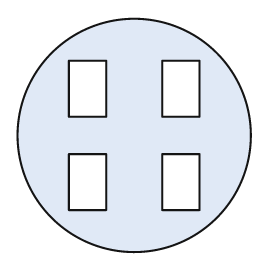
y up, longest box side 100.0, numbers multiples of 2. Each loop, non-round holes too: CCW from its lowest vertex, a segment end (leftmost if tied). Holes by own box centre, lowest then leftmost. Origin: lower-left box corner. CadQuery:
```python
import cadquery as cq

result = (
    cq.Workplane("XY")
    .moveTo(50.0, 50.0)
    .circle(50.0)
    .moveTo(22.0, 18.0)
    .lineTo(38.0, 18.0)
    .lineTo(38.0, 42.0)
    .lineTo(22.0, 42.0)
    .close()
    .moveTo(62.0, 18.0)
    .lineTo(78.0, 18.0)
    .lineTo(78.0, 42.0)
    .lineTo(62.0, 42.0)
    .close()
    .moveTo(22.0, 58.0)
    .lineTo(38.0, 58.0)
    .lineTo(38.0, 82.0)
    .lineTo(22.0, 82.0)
    .close()
    .moveTo(62.0, 58.0)
    .lineTo(78.0, 58.0)
    .lineTo(78.0, 82.0)
    .lineTo(62.0, 82.0)
    .close()
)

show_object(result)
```